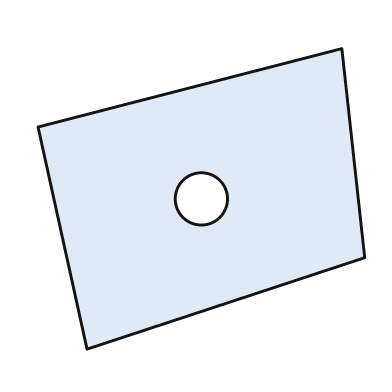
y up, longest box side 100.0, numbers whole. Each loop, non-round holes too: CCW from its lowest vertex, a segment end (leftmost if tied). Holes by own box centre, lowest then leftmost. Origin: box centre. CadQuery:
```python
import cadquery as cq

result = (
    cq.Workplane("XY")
    .moveTo(-35.0, -46.0)
    .lineTo(50.0, -18.0)
    .lineTo(43.0, 46.0)
    .lineTo(-50.0, 22.0)
    .close()
    .moveTo(0.0, 0.0)
    .circle(8.0)
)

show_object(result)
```